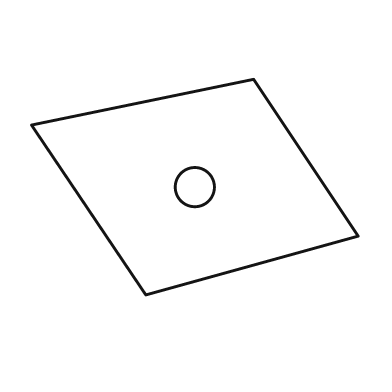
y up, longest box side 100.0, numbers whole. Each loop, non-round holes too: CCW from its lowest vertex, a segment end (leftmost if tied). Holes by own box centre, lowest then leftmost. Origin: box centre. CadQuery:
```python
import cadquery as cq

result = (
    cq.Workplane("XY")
    .moveTo(-15.0, -33.0)
    .lineTo(50.0, -15.0)
    .lineTo(18.0, 33.0)
    .lineTo(-50.0, 19.0)
    .close()
    .moveTo(0.0, 0.0)
    .circle(6.0)
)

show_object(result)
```